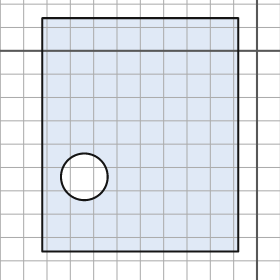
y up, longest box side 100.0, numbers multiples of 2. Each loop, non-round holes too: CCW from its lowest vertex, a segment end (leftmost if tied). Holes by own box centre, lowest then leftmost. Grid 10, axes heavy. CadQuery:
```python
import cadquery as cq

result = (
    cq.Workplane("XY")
    .moveTo(-92.0, -86.0)
    .lineTo(-8.0, -86.0)
    .lineTo(-8.0, 14.0)
    .lineTo(-92.0, 14.0)
    .close()
    .moveTo(-74.0, -54.0)
    .circle(10.0)
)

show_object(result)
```